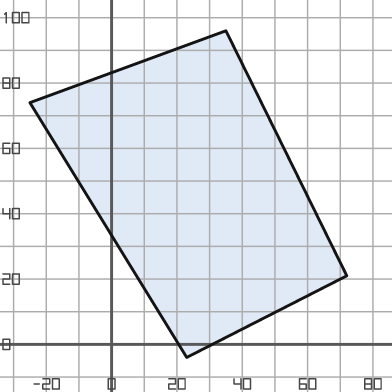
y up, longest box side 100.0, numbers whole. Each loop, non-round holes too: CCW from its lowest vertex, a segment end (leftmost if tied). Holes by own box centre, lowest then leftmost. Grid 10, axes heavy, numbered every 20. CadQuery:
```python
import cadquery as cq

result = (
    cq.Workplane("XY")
    .moveTo(23.0, -4.0)
    .lineTo(72.0, 21.0)
    .lineTo(35.0, 96.0)
    .lineTo(-25.0, 74.0)
    .close()
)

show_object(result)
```